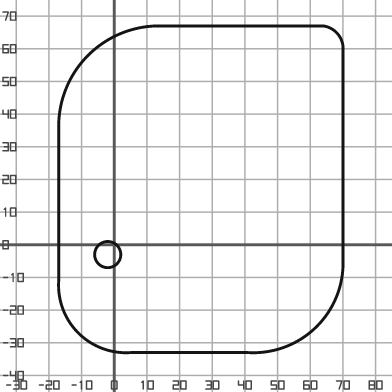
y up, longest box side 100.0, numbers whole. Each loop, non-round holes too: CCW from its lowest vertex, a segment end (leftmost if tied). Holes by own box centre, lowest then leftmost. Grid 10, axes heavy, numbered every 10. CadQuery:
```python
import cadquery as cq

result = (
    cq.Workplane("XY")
    .moveTo(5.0, -33.0)
    .lineTo(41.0, -33.0)
    .threePointArc((62.0, -25.0), (70.0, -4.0))
    .lineTo(70.0, 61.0)
    .threePointArc((68.0, 65.0), (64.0, 67.0))
    .lineTo(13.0, 67.0)
    .threePointArc((-8.0, 58.0), (-17.0, 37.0))
    .lineTo(-17.0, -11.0)
    .threePointArc((-11.0, -27.0), (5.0, -33.0))
    .close()
    .moveTo(-2.0, -3.0)
    .circle(4.0)
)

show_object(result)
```